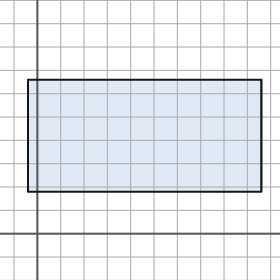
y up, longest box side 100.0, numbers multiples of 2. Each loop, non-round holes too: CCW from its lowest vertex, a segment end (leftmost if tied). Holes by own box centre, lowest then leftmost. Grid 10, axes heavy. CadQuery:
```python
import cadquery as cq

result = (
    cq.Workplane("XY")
    .moveTo(-4.0, 18.0)
    .lineTo(96.0, 18.0)
    .lineTo(96.0, 66.0)
    .lineTo(-4.0, 66.0)
    .close()
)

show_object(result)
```